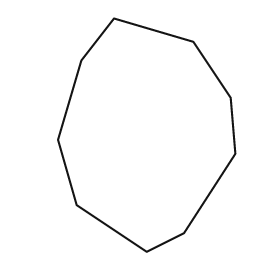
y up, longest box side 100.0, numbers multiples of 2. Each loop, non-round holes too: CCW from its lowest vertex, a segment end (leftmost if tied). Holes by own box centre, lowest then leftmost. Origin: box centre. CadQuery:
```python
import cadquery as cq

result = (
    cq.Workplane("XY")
    .moveTo(0.0, -50.0)
    .lineTo(16.0, -42.0)
    .lineTo(38.0, -8.0)
    .lineTo(36.0, 16.0)
    .lineTo(20.0, 40.0)
    .lineTo(-14.0, 50.0)
    .lineTo(-28.0, 32.0)
    .lineTo(-38.0, -2.0)
    .lineTo(-30.0, -30.0)
    .close()
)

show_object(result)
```